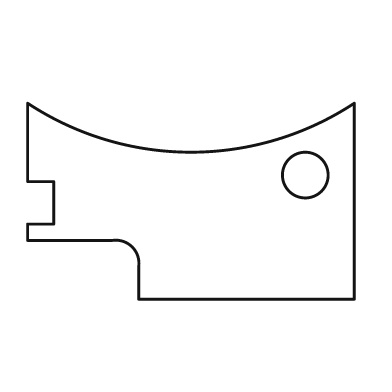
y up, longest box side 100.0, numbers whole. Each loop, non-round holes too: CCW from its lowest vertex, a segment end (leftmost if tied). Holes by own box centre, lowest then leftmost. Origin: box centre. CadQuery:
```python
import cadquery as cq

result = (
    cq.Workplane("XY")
    .moveTo(-16.0, -30.0)
    .lineTo(50.0, -30.0)
    .lineTo(50.0, 30.0)
    .threePointArc((0.0, 15.0), (-50.0, 30.0))
    .lineTo(-50.0, 6.0)
    .lineTo(-42.0, 6.0)
    .lineTo(-42.0, -7.0)
    .lineTo(-50.0, -7.0)
    .lineTo(-50.0, -12.0)
    .lineTo(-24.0, -12.0)
    .threePointArc((-18.0, -14.0), (-16.0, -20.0))
    .close()
    .moveTo(35.0, 8.0)
    .circle(7.0)
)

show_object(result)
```